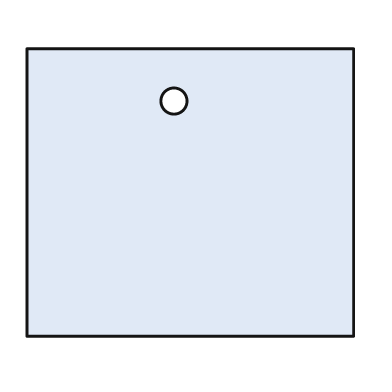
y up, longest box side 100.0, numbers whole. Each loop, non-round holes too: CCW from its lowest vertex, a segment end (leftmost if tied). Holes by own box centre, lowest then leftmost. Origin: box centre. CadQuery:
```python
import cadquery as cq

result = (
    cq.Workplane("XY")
    .moveTo(-50.0, -44.0)
    .lineTo(50.0, -44.0)
    .lineTo(50.0, 44.0)
    .lineTo(-50.0, 44.0)
    .close()
    .moveTo(-5.0, 28.0)
    .circle(4.0)
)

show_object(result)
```